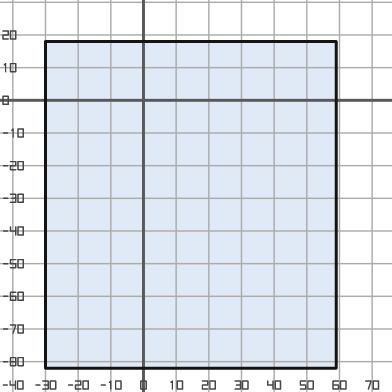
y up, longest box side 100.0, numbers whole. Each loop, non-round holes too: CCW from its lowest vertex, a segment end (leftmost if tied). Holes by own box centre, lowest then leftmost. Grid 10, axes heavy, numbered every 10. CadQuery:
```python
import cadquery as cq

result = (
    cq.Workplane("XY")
    .moveTo(-30.0, -82.0)
    .lineTo(59.0, -82.0)
    .lineTo(59.0, 18.0)
    .lineTo(-30.0, 18.0)
    .close()
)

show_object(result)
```